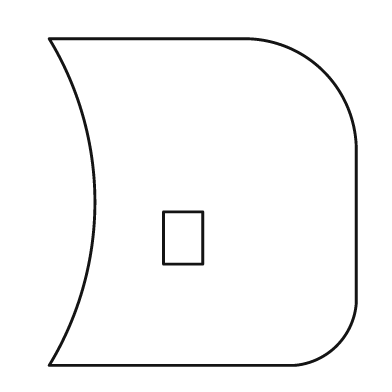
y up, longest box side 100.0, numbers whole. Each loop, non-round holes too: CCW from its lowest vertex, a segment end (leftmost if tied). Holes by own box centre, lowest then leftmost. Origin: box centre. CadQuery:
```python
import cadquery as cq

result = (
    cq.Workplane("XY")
    .moveTo(-47.0, -50.0)
    .lineTo(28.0, -50.0)
    .threePointArc((41.0, -44.0), (47.0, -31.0))
    .lineTo(47.0, 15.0)
    .threePointArc((37.0, 40.0), (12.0, 50.0))
    .lineTo(-47.0, 50.0)
    .threePointArc((-33.0, 0.0), (-47.0, -50.0))
    .close()
    .moveTo(-12.0, -19.0)
    .lineTo(0.0, -19.0)
    .lineTo(0.0, -3.0)
    .lineTo(-12.0, -3.0)
    .close()
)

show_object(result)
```